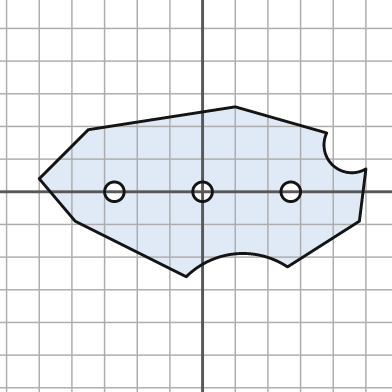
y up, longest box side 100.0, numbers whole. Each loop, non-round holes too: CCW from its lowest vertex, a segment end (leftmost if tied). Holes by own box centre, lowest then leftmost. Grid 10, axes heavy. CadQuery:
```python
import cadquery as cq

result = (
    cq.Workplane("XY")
    .moveTo(-5.0, -26.0)
    .threePointArc((10.0, -19.0), (26.0, -23.0))
    .lineTo(48.0, -9.0)
    .lineTo(50.0, 7.0)
    .threePointArc((40.0, 8.0), (38.0, 18.0))
    .lineTo(10.0, 26.0)
    .lineTo(-35.0, 19.0)
    .lineTo(-50.0, 4.0)
    .lineTo(-39.0, -9.0)
    .close()
    .moveTo(-27.0, 0.0)
    .circle(3.0)
    .moveTo(0.0, 0.0)
    .circle(3.0)
    .moveTo(27.0, 0.0)
    .circle(3.0)
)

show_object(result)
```